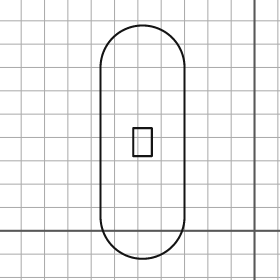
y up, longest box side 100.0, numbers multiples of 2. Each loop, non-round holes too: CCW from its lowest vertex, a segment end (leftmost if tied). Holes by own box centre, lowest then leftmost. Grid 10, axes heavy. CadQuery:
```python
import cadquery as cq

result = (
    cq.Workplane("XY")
    .moveTo(-66.0, 6.0)
    .threePointArc((-48.0, -12.0), (-30.0, 6.0))
    .lineTo(-30.0, 70.0)
    .threePointArc((-48.0, 88.0), (-66.0, 70.0))
    .close()
    .moveTo(-52.0, 32.0)
    .lineTo(-44.0, 32.0)
    .lineTo(-44.0, 44.0)
    .lineTo(-52.0, 44.0)
    .close()
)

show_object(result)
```